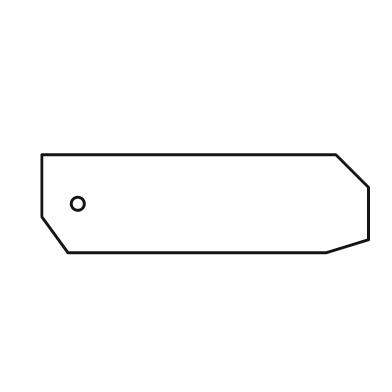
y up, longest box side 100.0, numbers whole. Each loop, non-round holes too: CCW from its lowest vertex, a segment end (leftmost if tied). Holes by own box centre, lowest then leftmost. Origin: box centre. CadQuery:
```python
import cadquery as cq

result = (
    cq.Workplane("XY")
    .moveTo(-42.0, -15.0)
    .lineTo(37.0, -15.0)
    .lineTo(50.0, -11.0)
    .lineTo(50.0, 5.0)
    .lineTo(40.0, 15.0)
    .lineTo(-50.0, 15.0)
    .lineTo(-50.0, -4.0)
    .close()
    .moveTo(-39.0, 0.0)
    .circle(2.0)
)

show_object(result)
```